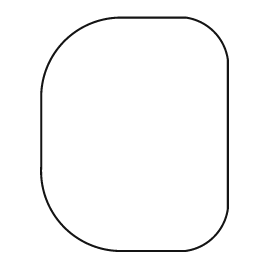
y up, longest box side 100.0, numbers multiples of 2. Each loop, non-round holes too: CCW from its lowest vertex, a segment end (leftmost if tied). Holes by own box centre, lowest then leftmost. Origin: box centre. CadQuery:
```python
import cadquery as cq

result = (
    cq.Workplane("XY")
    .moveTo(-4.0, -50.0)
    .lineTo(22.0, -50.0)
    .threePointArc((34.0, -44.0), (40.0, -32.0))
    .lineTo(40.0, 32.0)
    .threePointArc((34.0, 44.0), (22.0, 50.0))
    .lineTo(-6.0, 50.0)
    .threePointArc((-30.0, 40.0), (-40.0, 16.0))
    .lineTo(-40.0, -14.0)
    .threePointArc((-30.0, -40.0), (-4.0, -50.0))
    .close()
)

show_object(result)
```